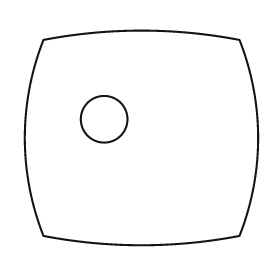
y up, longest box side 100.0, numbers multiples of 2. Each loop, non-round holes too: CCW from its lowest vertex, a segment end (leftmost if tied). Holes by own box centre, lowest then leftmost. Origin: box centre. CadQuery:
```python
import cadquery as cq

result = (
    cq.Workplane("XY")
    .moveTo(-42.0, -42.0)
    .threePointArc((0.0, -46.0), (42.0, -42.0))
    .threePointArc((50.0, 0.0), (42.0, 42.0))
    .threePointArc((0.0, 46.0), (-42.0, 42.0))
    .threePointArc((-50.0, 0.0), (-42.0, -42.0))
    .close()
    .moveTo(-16.0, 8.0)
    .circle(10.0)
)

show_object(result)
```